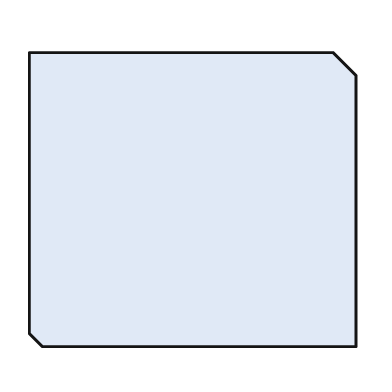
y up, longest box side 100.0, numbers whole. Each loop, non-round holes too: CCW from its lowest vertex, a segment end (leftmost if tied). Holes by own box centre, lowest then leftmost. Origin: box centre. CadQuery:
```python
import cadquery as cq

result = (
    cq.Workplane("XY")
    .moveTo(-46.0, -45.0)
    .lineTo(50.0, -45.0)
    .lineTo(50.0, 38.0)
    .lineTo(43.0, 45.0)
    .lineTo(-50.0, 45.0)
    .lineTo(-50.0, -41.0)
    .close()
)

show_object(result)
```